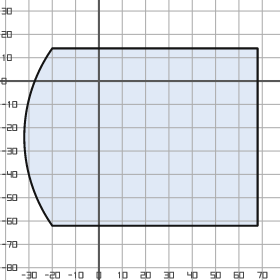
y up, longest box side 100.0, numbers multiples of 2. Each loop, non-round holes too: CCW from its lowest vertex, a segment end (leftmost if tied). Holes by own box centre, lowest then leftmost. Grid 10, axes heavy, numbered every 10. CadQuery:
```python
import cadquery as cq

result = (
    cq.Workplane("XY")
    .moveTo(-20.0, -62.0)
    .lineTo(68.0, -62.0)
    .lineTo(68.0, 14.0)
    .lineTo(-20.0, 14.0)
    .threePointArc((-32.0, -24.0), (-20.0, -62.0))
    .close()
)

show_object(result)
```